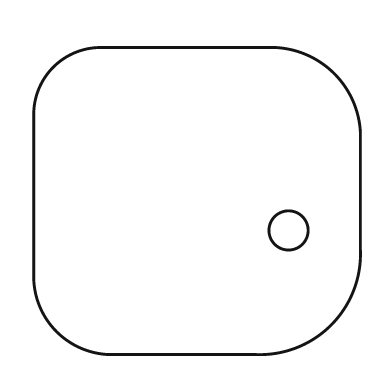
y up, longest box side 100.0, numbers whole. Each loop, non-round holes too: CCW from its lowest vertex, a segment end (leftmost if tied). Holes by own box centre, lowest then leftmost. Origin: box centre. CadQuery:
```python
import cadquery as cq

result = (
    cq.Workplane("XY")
    .moveTo(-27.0, -47.0)
    .lineTo(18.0, -47.0)
    .threePointArc((41.0, -38.0), (50.0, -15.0))
    .lineTo(50.0, 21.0)
    .threePointArc((42.0, 39.0), (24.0, 47.0))
    .lineTo(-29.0, 47.0)
    .threePointArc((-44.0, 41.0), (-50.0, 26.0))
    .lineTo(-50.0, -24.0)
    .threePointArc((-43.0, -40.0), (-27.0, -47.0))
    .close()
    .moveTo(28.0, -9.0)
    .circle(6.0)
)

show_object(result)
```